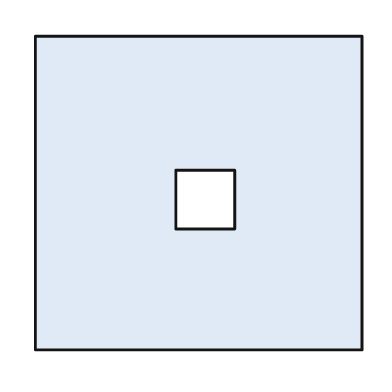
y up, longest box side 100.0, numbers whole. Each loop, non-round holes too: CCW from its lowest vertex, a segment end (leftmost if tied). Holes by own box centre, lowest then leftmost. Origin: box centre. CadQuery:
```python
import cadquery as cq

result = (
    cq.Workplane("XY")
    .moveTo(-50.0, -48.0)
    .lineTo(50.0, -48.0)
    .lineTo(50.0, 48.0)
    .lineTo(-50.0, 48.0)
    .close()
    .moveTo(-7.0, -11.0)
    .lineTo(11.0, -11.0)
    .lineTo(11.0, 7.0)
    .lineTo(-7.0, 7.0)
    .close()
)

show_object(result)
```